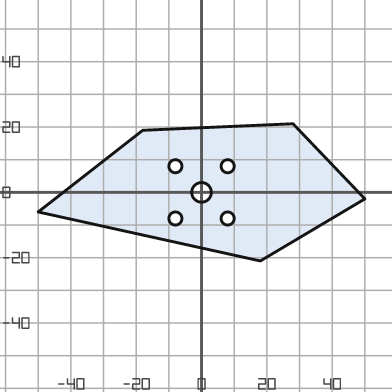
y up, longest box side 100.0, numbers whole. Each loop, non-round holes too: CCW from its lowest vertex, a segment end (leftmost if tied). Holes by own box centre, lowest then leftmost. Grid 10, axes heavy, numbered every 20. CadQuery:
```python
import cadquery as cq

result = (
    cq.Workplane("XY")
    .moveTo(18.0, -21.0)
    .lineTo(50.0, -2.0)
    .lineTo(28.0, 21.0)
    .lineTo(-18.0, 19.0)
    .lineTo(-50.0, -6.0)
    .close()
    .moveTo(-8.0, -8.0)
    .circle(2.0)
    .moveTo(8.0, -8.0)
    .circle(2.0)
    .moveTo(0.0, 0.0)
    .circle(3.0)
    .moveTo(-8.0, 8.0)
    .circle(2.0)
    .moveTo(8.0, 8.0)
    .circle(2.0)
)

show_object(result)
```